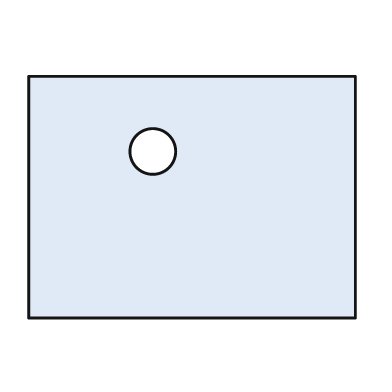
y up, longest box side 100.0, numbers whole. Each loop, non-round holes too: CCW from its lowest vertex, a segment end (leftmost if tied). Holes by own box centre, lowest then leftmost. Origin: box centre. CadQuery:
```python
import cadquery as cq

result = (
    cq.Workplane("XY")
    .moveTo(-50.0, -37.0)
    .lineTo(50.0, -37.0)
    .lineTo(50.0, 37.0)
    .lineTo(-50.0, 37.0)
    .close()
    .moveTo(-12.0, 14.0)
    .circle(7.0)
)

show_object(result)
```